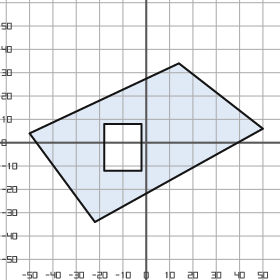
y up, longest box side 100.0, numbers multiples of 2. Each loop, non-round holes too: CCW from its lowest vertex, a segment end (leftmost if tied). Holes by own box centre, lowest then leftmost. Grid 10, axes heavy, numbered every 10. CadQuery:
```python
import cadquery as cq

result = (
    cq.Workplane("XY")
    .moveTo(-22.0, -34.0)
    .lineTo(50.0, 6.0)
    .lineTo(14.0, 34.0)
    .lineTo(-50.0, 4.0)
    .close()
    .moveTo(-18.0, -12.0)
    .lineTo(-2.0, -12.0)
    .lineTo(-2.0, 8.0)
    .lineTo(-18.0, 8.0)
    .close()
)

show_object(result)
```